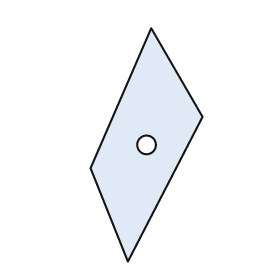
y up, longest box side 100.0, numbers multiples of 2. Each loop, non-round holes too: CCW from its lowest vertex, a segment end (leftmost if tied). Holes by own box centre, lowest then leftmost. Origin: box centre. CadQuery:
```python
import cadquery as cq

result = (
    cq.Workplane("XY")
    .moveTo(-8.0, -50.0)
    .lineTo(24.0, 12.0)
    .lineTo(2.0, 50.0)
    .lineTo(-24.0, -10.0)
    .close()
    .moveTo(0.0, 0.0)
    .circle(4.0)
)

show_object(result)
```